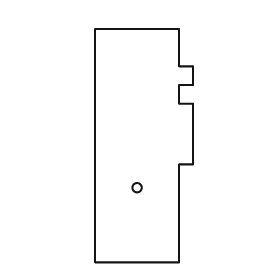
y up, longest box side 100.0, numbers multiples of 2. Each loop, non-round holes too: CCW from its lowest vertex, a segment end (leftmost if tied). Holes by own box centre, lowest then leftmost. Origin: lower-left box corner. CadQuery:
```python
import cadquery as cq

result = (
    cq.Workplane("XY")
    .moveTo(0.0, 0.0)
    .lineTo(36.0, 0.0)
    .lineTo(36.0, 42.0)
    .lineTo(42.0, 42.0)
    .lineTo(42.0, 68.0)
    .lineTo(36.0, 68.0)
    .lineTo(36.0, 76.0)
    .lineTo(42.0, 76.0)
    .lineTo(42.0, 84.0)
    .lineTo(36.0, 84.0)
    .lineTo(36.0, 100.0)
    .lineTo(0.0, 100.0)
    .close()
    .moveTo(18.0, 32.0)
    .circle(2.0)
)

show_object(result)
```